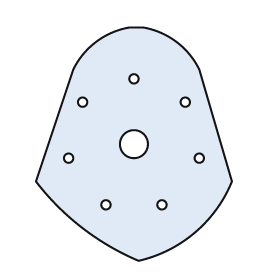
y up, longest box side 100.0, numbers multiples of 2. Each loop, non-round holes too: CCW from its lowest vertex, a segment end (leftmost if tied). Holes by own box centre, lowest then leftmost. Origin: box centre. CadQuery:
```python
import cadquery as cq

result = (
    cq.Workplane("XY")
    .moveTo(2.0, -50.0)
    .threePointArc((26.0, -38.0), (42.0, -16.0))
    .lineTo(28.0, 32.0)
    .threePointArc((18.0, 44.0), (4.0, 50.0))
    .lineTo(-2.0, 50.0)
    .threePointArc((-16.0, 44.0), (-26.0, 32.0))
    .lineTo(-42.0, -16.0)
    .threePointArc((-22.0, -36.0), (2.0, -50.0))
    .close()
    .moveTo(-12.0, -26.0)
    .circle(2.0)
    .moveTo(12.0, -26.0)
    .circle(2.0)
    .moveTo(-28.0, -6.0)
    .circle(2.0)
    .moveTo(28.0, -6.0)
    .circle(2.0)
    .moveTo(0.0, 0.0)
    .circle(6.0)
    .moveTo(-22.0, 18.0)
    .circle(2.0)
    .moveTo(22.0, 18.0)
    .circle(2.0)
    .moveTo(0.0, 28.0)
    .circle(2.0)
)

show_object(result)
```